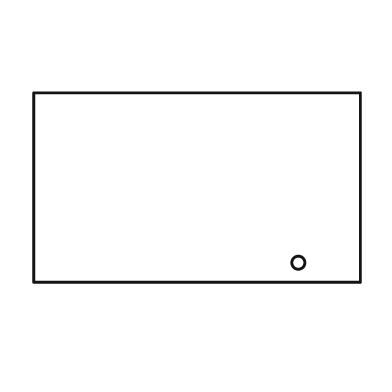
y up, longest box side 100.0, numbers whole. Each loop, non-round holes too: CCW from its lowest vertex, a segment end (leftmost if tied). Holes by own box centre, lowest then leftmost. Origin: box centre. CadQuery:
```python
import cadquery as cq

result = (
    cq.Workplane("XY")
    .moveTo(-50.0, -29.0)
    .lineTo(50.0, -29.0)
    .lineTo(50.0, 29.0)
    .lineTo(-50.0, 29.0)
    .close()
    .moveTo(31.0, -23.0)
    .circle(2.0)
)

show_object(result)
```